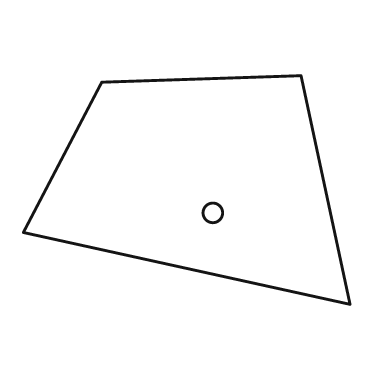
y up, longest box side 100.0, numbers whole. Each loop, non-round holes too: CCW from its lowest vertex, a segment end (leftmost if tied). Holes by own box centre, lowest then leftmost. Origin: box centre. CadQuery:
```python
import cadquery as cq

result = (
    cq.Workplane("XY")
    .moveTo(50.0, -35.0)
    .lineTo(35.0, 35.0)
    .lineTo(-26.0, 33.0)
    .lineTo(-50.0, -13.0)
    .close()
    .moveTo(8.0, -7.0)
    .circle(3.0)
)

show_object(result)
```